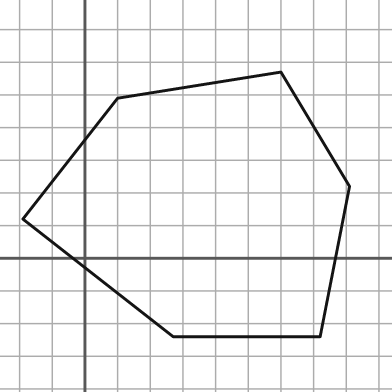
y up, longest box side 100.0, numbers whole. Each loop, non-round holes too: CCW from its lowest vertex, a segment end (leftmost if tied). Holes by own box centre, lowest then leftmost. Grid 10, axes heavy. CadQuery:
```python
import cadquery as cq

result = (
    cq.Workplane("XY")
    .moveTo(27.0, -24.0)
    .lineTo(72.0, -24.0)
    .lineTo(81.0, 22.0)
    .lineTo(60.0, 57.0)
    .lineTo(10.0, 49.0)
    .lineTo(-19.0, 12.0)
    .close()
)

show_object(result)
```